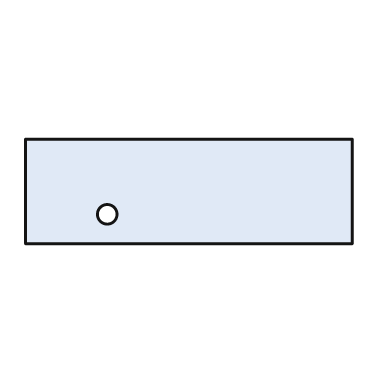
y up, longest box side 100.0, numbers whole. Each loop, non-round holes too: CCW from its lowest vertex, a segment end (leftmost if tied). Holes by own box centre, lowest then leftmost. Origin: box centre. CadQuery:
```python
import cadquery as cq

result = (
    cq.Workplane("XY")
    .moveTo(-50.0, -16.0)
    .lineTo(50.0, -16.0)
    .lineTo(50.0, 16.0)
    .lineTo(-50.0, 16.0)
    .close()
    .moveTo(-25.0, -7.0)
    .circle(3.0)
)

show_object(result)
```